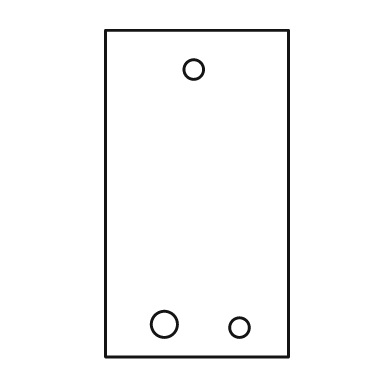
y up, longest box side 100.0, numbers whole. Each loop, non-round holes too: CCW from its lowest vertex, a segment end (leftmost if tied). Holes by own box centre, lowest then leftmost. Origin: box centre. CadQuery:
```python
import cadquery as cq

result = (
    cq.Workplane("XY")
    .moveTo(-28.0, -50.0)
    .lineTo(28.0, -50.0)
    .lineTo(28.0, 50.0)
    .lineTo(-28.0, 50.0)
    .close()
    .moveTo(13.0, -41.0)
    .circle(3.0)
    .moveTo(-10.0, -40.0)
    .circle(4.0)
    .moveTo(-1.0, 38.0)
    .circle(3.0)
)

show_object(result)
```